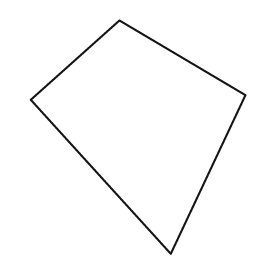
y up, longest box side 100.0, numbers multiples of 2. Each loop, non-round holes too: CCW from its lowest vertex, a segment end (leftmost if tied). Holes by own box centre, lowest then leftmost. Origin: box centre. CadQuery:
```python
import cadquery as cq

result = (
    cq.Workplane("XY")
    .moveTo(14.0, -50.0)
    .lineTo(46.0, 18.0)
    .lineTo(-8.0, 50.0)
    .lineTo(-46.0, 16.0)
    .close()
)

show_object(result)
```